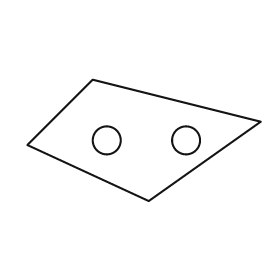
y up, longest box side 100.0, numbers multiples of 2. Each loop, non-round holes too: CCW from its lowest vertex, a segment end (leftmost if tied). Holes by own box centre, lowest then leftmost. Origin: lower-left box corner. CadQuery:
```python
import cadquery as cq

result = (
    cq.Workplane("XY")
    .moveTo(52.0, 0.0)
    .lineTo(100.0, 34.0)
    .lineTo(28.0, 52.0)
    .lineTo(0.0, 24.0)
    .close()
    .moveTo(34.0, 26.0)
    .circle(6.0)
    .moveTo(68.0, 26.0)
    .circle(6.0)
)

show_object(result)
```